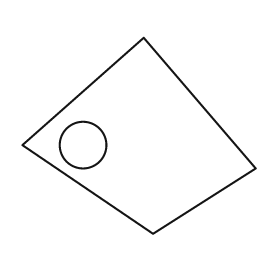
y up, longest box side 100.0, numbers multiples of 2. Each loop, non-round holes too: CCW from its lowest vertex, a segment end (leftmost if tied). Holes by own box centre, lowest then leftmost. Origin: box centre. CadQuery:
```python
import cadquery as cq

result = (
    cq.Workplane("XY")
    .moveTo(6.0, -42.0)
    .lineTo(50.0, -14.0)
    .lineTo(2.0, 42.0)
    .lineTo(-50.0, -4.0)
    .close()
    .moveTo(-24.0, -4.0)
    .circle(10.0)
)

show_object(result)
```